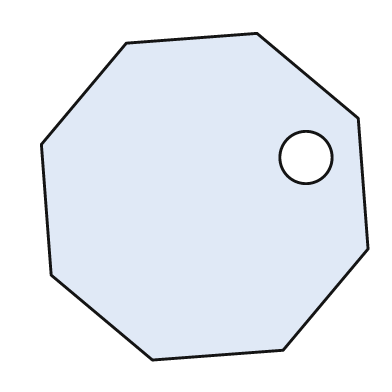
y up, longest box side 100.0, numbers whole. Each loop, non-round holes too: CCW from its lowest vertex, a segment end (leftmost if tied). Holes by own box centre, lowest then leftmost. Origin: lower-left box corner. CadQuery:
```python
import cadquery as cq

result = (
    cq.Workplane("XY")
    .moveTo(34.0, 0.0)
    .lineTo(74.0, 3.0)
    .lineTo(100.0, 34.0)
    .lineTo(97.0, 74.0)
    .lineTo(66.0, 100.0)
    .lineTo(26.0, 97.0)
    .lineTo(0.0, 66.0)
    .lineTo(3.0, 26.0)
    .close()
    .moveTo(81.0, 62.0)
    .circle(8.0)
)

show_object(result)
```